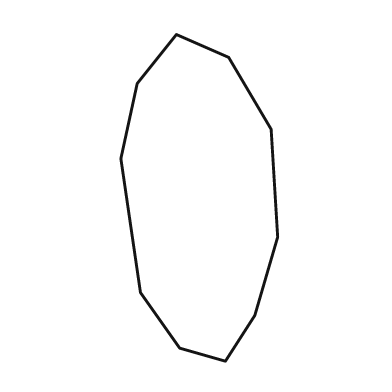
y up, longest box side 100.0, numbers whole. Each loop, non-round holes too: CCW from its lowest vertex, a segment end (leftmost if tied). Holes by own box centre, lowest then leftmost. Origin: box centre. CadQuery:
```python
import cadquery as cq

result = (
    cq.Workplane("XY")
    .moveTo(8.0, -50.0)
    .lineTo(17.0, -36.0)
    .lineTo(24.0, -12.0)
    .lineTo(22.0, 21.0)
    .lineTo(9.0, 43.0)
    .lineTo(-7.0, 50.0)
    .lineTo(-19.0, 35.0)
    .lineTo(-24.0, 12.0)
    .lineTo(-18.0, -29.0)
    .lineTo(-6.0, -46.0)
    .close()
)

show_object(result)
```